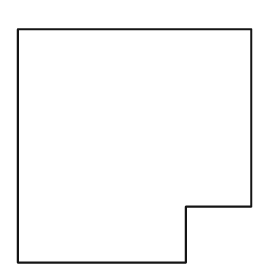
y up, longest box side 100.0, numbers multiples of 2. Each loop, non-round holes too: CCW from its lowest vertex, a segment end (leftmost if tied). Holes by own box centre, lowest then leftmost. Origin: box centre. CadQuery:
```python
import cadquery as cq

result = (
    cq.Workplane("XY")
    .moveTo(-50.0, -50.0)
    .lineTo(22.0, -50.0)
    .lineTo(22.0, -26.0)
    .lineTo(50.0, -26.0)
    .lineTo(50.0, 50.0)
    .lineTo(-50.0, 50.0)
    .close()
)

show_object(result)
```